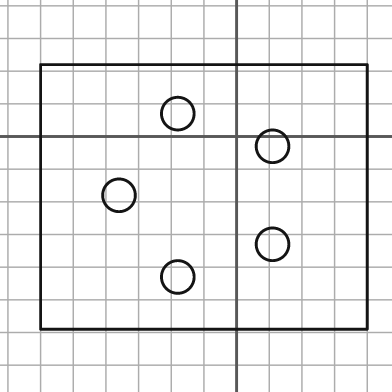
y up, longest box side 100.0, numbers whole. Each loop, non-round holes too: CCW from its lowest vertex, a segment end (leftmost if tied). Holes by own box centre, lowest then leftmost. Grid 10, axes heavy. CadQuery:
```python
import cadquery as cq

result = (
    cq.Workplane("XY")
    .moveTo(-60.0, -59.0)
    .lineTo(40.0, -59.0)
    .lineTo(40.0, 22.0)
    .lineTo(-60.0, 22.0)
    .close()
    .moveTo(-18.0, -43.0)
    .circle(5.0)
    .moveTo(11.0, -33.0)
    .circle(5.0)
    .moveTo(-36.0, -18.0)
    .circle(5.0)
    .moveTo(11.0, -3.0)
    .circle(5.0)
    .moveTo(-18.0, 7.0)
    .circle(5.0)
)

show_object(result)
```